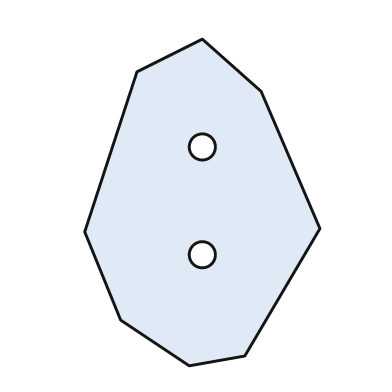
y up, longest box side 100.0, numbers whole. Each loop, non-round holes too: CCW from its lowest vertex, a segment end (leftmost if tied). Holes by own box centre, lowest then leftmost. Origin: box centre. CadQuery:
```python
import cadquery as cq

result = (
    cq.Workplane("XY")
    .moveTo(-4.0, -50.0)
    .lineTo(13.0, -47.0)
    .lineTo(36.0, -8.0)
    .lineTo(18.0, 34.0)
    .lineTo(0.0, 50.0)
    .lineTo(-20.0, 40.0)
    .lineTo(-36.0, -9.0)
    .lineTo(-25.0, -36.0)
    .close()
    .moveTo(0.0, -16.0)
    .circle(4.0)
    .moveTo(0.0, 17.0)
    .circle(4.0)
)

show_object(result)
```